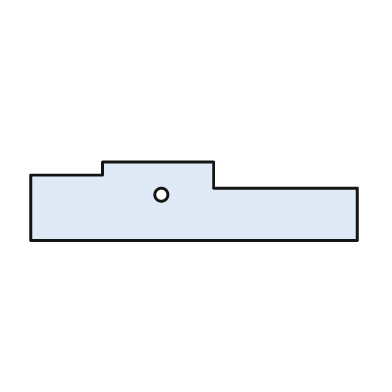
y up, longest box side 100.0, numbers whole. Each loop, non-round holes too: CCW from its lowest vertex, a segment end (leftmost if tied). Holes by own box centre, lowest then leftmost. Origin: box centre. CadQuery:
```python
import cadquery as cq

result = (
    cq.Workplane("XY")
    .moveTo(-50.0, -12.0)
    .lineTo(50.0, -12.0)
    .lineTo(50.0, 4.0)
    .lineTo(6.0, 4.0)
    .lineTo(6.0, 12.0)
    .lineTo(-28.0, 12.0)
    .lineTo(-28.0, 8.0)
    .lineTo(-50.0, 8.0)
    .close()
    .moveTo(-10.0, 2.0)
    .circle(2.0)
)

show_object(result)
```